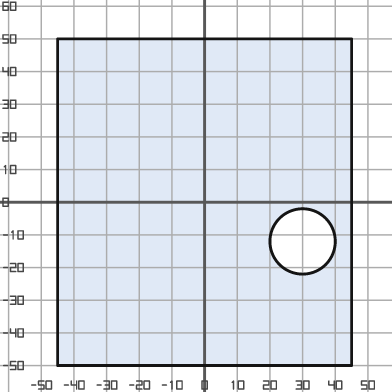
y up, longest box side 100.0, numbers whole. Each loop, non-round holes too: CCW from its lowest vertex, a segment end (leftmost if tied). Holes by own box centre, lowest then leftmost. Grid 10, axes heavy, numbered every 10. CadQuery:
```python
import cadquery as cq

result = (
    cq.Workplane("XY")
    .moveTo(-45.0, -50.0)
    .lineTo(45.0, -50.0)
    .lineTo(45.0, 50.0)
    .lineTo(-45.0, 50.0)
    .close()
    .moveTo(30.0, -12.0)
    .circle(10.0)
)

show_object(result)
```